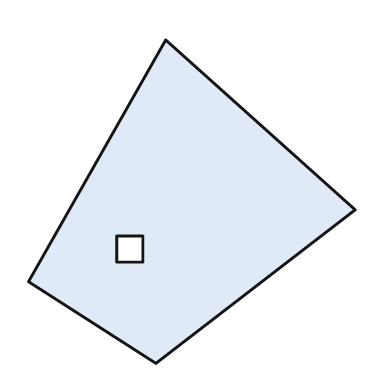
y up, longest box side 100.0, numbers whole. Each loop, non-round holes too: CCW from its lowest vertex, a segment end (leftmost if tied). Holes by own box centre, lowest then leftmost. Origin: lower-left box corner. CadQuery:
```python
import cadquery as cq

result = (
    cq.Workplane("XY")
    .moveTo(39.0, 0.0)
    .lineTo(100.0, 47.0)
    .lineTo(42.0, 99.0)
    .lineTo(0.0, 25.0)
    .close()
    .moveTo(27.0, 31.0)
    .lineTo(35.0, 31.0)
    .lineTo(35.0, 39.0)
    .lineTo(27.0, 39.0)
    .close()
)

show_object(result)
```